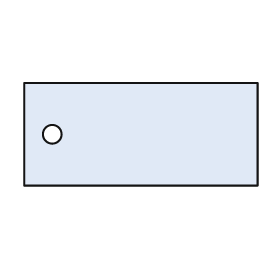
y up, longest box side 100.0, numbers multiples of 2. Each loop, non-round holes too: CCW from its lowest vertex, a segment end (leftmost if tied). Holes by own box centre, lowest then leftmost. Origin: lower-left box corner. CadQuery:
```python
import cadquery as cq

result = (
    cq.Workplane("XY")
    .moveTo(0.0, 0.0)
    .lineTo(100.0, 0.0)
    .lineTo(100.0, 44.0)
    .lineTo(0.0, 44.0)
    .close()
    .moveTo(12.0, 22.0)
    .circle(4.0)
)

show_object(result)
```